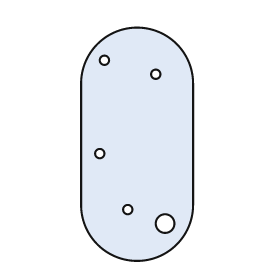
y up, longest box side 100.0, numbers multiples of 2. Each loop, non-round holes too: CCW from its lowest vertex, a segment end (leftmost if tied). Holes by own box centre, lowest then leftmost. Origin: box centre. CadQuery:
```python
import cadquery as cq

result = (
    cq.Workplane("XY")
    .moveTo(-24.0, -26.0)
    .threePointArc((0.0, -50.0), (24.0, -26.0))
    .lineTo(24.0, 26.0)
    .threePointArc((0.0, 50.0), (-24.0, 26.0))
    .close()
    .moveTo(12.0, -34.0)
    .circle(4.0)
    .moveTo(-4.0, -28.0)
    .circle(2.0)
    .moveTo(-16.0, -4.0)
    .circle(2.0)
    .moveTo(8.0, 30.0)
    .circle(2.0)
    .moveTo(-14.0, 36.0)
    .circle(2.0)
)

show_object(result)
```